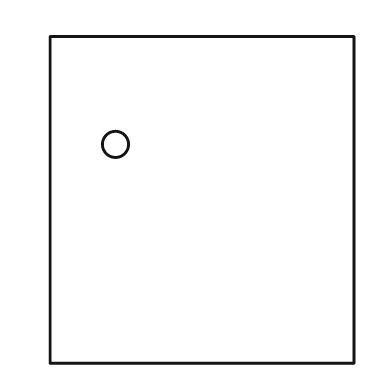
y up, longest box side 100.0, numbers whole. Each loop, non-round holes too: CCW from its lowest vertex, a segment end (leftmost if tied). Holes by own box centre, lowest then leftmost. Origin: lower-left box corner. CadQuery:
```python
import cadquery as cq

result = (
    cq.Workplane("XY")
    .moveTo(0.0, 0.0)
    .lineTo(93.0, 0.0)
    .lineTo(93.0, 100.0)
    .lineTo(0.0, 100.0)
    .close()
    .moveTo(20.0, 67.0)
    .circle(4.0)
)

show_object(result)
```